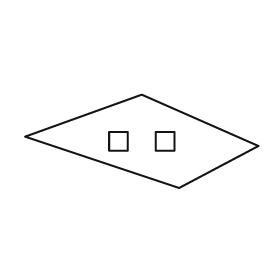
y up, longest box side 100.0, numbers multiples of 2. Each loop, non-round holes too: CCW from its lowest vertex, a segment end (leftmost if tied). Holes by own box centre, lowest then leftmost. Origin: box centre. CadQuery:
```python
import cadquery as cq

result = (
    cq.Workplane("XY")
    .moveTo(16.0, -20.0)
    .lineTo(50.0, -2.0)
    .lineTo(0.0, 20.0)
    .lineTo(-50.0, 2.0)
    .close()
    .moveTo(-14.0, -4.0)
    .lineTo(-6.0, -4.0)
    .lineTo(-6.0, 4.0)
    .lineTo(-14.0, 4.0)
    .close()
    .moveTo(6.0, -4.0)
    .lineTo(14.0, -4.0)
    .lineTo(14.0, 4.0)
    .lineTo(6.0, 4.0)
    .close()
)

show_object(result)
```